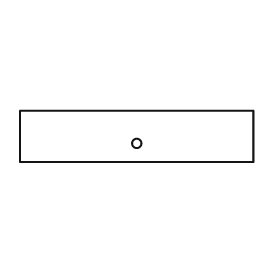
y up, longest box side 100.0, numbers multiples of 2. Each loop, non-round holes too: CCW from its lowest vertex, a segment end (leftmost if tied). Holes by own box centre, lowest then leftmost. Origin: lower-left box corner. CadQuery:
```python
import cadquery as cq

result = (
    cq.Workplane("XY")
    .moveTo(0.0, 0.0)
    .lineTo(100.0, 0.0)
    .lineTo(100.0, 22.0)
    .lineTo(0.0, 22.0)
    .close()
    .moveTo(50.0, 8.0)
    .circle(2.0)
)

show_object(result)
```